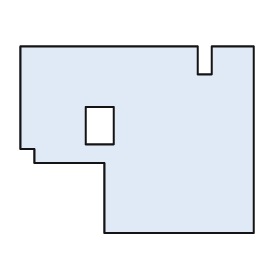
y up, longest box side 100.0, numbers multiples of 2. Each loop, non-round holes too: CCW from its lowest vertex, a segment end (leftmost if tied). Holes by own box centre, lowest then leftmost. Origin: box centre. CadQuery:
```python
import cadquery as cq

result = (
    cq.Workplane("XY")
    .moveTo(-14.0, -40.0)
    .lineTo(50.0, -40.0)
    .lineTo(50.0, 40.0)
    .lineTo(32.0, 40.0)
    .lineTo(32.0, 28.0)
    .lineTo(26.0, 28.0)
    .lineTo(26.0, 40.0)
    .lineTo(-50.0, 40.0)
    .lineTo(-50.0, -4.0)
    .lineTo(-44.0, -4.0)
    .lineTo(-44.0, -10.0)
    .lineTo(-14.0, -10.0)
    .close()
    .moveTo(-22.0, -2.0)
    .lineTo(-10.0, -2.0)
    .lineTo(-10.0, 14.0)
    .lineTo(-22.0, 14.0)
    .close()
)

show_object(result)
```